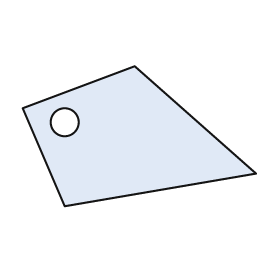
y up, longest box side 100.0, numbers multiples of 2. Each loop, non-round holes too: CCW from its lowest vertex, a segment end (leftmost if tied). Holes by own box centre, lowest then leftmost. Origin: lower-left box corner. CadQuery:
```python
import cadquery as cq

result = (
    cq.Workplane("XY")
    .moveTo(18.0, 0.0)
    .lineTo(100.0, 14.0)
    .lineTo(48.0, 60.0)
    .lineTo(0.0, 42.0)
    .close()
    .moveTo(18.0, 36.0)
    .circle(6.0)
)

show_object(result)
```